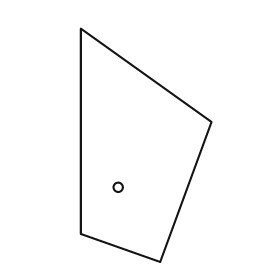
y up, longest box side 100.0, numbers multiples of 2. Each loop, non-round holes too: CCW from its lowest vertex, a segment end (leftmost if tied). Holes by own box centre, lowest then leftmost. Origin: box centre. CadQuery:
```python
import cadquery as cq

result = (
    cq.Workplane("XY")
    .moveTo(6.0, -50.0)
    .lineTo(28.0, 10.0)
    .lineTo(-28.0, 50.0)
    .lineTo(-28.0, -38.0)
    .close()
    .moveTo(-12.0, -18.0)
    .circle(2.0)
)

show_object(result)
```